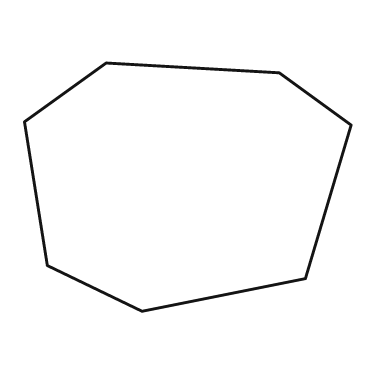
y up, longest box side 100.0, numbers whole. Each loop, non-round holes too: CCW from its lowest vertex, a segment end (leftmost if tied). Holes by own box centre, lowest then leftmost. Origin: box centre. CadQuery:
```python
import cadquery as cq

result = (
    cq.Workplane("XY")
    .moveTo(-14.0, -38.0)
    .lineTo(36.0, -28.0)
    .lineTo(50.0, 19.0)
    .lineTo(28.0, 35.0)
    .lineTo(-25.0, 38.0)
    .lineTo(-50.0, 20.0)
    .lineTo(-43.0, -24.0)
    .close()
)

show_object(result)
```